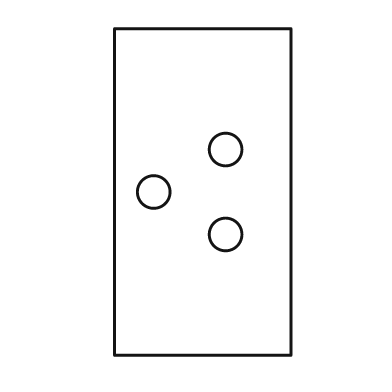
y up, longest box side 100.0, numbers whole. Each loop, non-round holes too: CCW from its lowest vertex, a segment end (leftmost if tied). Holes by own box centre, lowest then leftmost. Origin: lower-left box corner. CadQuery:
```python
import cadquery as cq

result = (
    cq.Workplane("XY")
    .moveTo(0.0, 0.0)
    .lineTo(54.0, 0.0)
    .lineTo(54.0, 100.0)
    .lineTo(0.0, 100.0)
    .close()
    .moveTo(34.0, 37.0)
    .circle(5.0)
    .moveTo(12.0, 50.0)
    .circle(5.0)
    .moveTo(34.0, 63.0)
    .circle(5.0)
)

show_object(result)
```